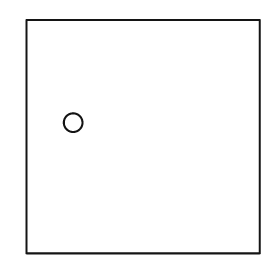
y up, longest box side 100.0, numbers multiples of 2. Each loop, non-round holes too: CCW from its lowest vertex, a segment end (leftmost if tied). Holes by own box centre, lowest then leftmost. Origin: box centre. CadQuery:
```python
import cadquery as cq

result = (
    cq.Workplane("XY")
    .moveTo(-50.0, -50.0)
    .lineTo(50.0, -50.0)
    .lineTo(50.0, 50.0)
    .lineTo(-50.0, 50.0)
    .close()
    .moveTo(-30.0, 6.0)
    .circle(4.0)
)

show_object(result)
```